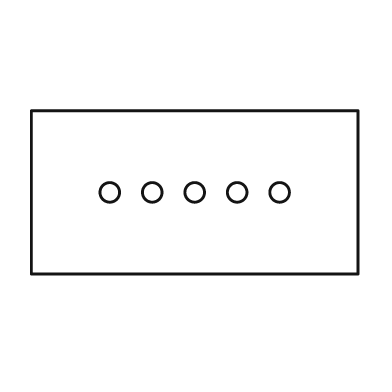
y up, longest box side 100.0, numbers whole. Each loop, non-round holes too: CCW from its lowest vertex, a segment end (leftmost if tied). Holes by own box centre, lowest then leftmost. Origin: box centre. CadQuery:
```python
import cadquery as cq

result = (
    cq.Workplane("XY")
    .moveTo(-50.0, -25.0)
    .lineTo(50.0, -25.0)
    .lineTo(50.0, 25.0)
    .lineTo(-50.0, 25.0)
    .close()
    .moveTo(-26.0, 0.0)
    .circle(3.0)
    .moveTo(-13.0, 0.0)
    .circle(3.0)
    .moveTo(0.0, 0.0)
    .circle(3.0)
    .moveTo(13.0, 0.0)
    .circle(3.0)
    .moveTo(26.0, 0.0)
    .circle(3.0)
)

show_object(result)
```